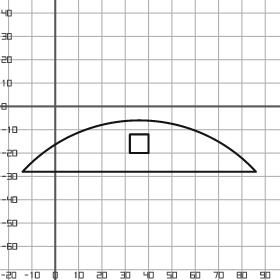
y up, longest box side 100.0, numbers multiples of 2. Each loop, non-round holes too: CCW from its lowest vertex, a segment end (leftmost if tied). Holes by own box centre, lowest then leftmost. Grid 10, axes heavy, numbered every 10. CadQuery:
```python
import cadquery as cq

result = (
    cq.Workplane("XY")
    .moveTo(-14.0, -28.0)
    .lineTo(86.0, -28.0)
    .threePointArc((36.0, -6.0), (-14.0, -28.0))
    .close()
    .moveTo(32.0, -20.0)
    .lineTo(40.0, -20.0)
    .lineTo(40.0, -12.0)
    .lineTo(32.0, -12.0)
    .close()
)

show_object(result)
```